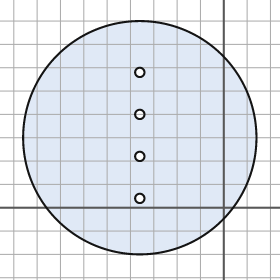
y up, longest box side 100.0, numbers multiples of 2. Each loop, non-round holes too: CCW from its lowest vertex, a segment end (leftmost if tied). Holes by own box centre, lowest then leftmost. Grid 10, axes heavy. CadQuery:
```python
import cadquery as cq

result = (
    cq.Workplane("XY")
    .moveTo(-36.0, 30.0)
    .circle(50.0)
    .moveTo(-36.0, 4.0)
    .circle(2.0)
    .moveTo(-36.0, 22.0)
    .circle(2.0)
    .moveTo(-36.0, 40.0)
    .circle(2.0)
    .moveTo(-36.0, 58.0)
    .circle(2.0)
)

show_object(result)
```